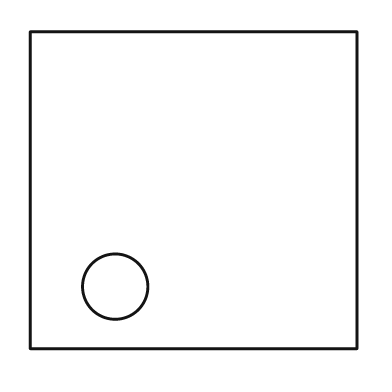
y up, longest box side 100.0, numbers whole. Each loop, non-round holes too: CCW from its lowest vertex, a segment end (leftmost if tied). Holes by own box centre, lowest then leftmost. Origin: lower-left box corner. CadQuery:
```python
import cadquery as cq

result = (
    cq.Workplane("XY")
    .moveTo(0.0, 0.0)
    .lineTo(100.0, 0.0)
    .lineTo(100.0, 97.0)
    .lineTo(0.0, 97.0)
    .close()
    .moveTo(26.0, 19.0)
    .circle(10.0)
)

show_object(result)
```